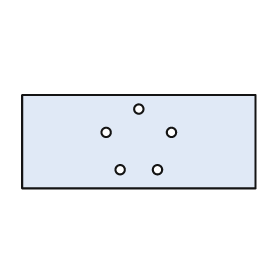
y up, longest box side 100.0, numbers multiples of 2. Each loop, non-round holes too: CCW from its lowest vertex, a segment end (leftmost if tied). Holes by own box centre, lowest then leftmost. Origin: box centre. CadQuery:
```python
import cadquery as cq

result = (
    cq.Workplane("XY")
    .moveTo(-50.0, -20.0)
    .lineTo(50.0, -20.0)
    .lineTo(50.0, 20.0)
    .lineTo(-50.0, 20.0)
    .close()
    .moveTo(-8.0, -12.0)
    .circle(2.0)
    .moveTo(8.0, -12.0)
    .circle(2.0)
    .moveTo(-14.0, 4.0)
    .circle(2.0)
    .moveTo(14.0, 4.0)
    .circle(2.0)
    .moveTo(0.0, 14.0)
    .circle(2.0)
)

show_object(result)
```